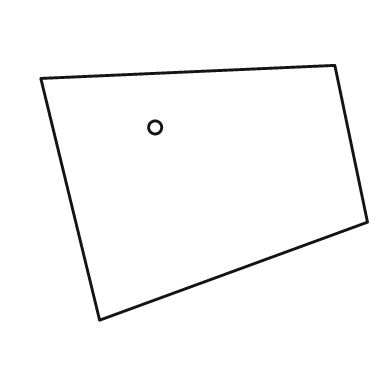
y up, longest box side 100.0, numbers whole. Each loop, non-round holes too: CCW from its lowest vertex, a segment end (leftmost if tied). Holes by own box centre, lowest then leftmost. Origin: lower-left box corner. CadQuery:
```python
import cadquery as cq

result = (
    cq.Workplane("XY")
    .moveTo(18.0, 0.0)
    .lineTo(100.0, 30.0)
    .lineTo(90.0, 78.0)
    .lineTo(0.0, 74.0)
    .close()
    .moveTo(35.0, 59.0)
    .circle(2.0)
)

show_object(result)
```